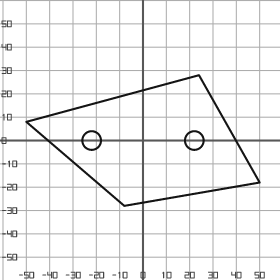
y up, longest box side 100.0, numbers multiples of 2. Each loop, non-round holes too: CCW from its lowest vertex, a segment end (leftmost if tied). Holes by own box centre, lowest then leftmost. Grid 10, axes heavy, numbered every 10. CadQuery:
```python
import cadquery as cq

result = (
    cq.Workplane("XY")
    .moveTo(-8.0, -28.0)
    .lineTo(50.0, -18.0)
    .lineTo(24.0, 28.0)
    .lineTo(-50.0, 8.0)
    .close()
    .moveTo(-22.0, 0.0)
    .circle(4.0)
    .moveTo(22.0, 0.0)
    .circle(4.0)
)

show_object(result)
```